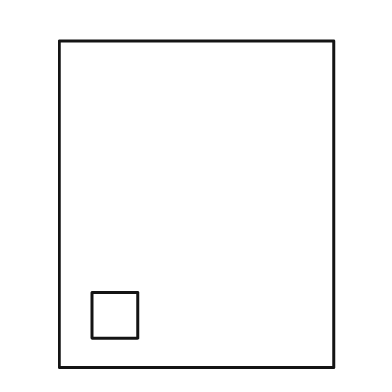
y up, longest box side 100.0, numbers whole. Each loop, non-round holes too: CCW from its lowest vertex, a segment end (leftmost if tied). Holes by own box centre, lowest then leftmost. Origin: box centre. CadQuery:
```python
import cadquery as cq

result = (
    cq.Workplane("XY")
    .moveTo(-42.0, -50.0)
    .lineTo(42.0, -50.0)
    .lineTo(42.0, 50.0)
    .lineTo(-42.0, 50.0)
    .close()
    .moveTo(-32.0, -41.0)
    .lineTo(-18.0, -41.0)
    .lineTo(-18.0, -27.0)
    .lineTo(-32.0, -27.0)
    .close()
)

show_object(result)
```